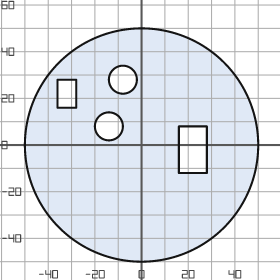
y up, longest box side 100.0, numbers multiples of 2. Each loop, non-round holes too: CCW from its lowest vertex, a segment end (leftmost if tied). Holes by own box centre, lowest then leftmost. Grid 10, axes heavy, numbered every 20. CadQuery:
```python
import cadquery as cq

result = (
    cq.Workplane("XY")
    .moveTo(0.0, 0.0)
    .circle(50.0)
    .moveTo(16.0, -12.0)
    .lineTo(28.0, -12.0)
    .lineTo(28.0, 8.0)
    .lineTo(16.0, 8.0)
    .close()
    .moveTo(-14.0, 8.0)
    .circle(6.0)
    .moveTo(-36.0, 16.0)
    .lineTo(-28.0, 16.0)
    .lineTo(-28.0, 28.0)
    .lineTo(-36.0, 28.0)
    .close()
    .moveTo(-8.0, 28.0)
    .circle(6.0)
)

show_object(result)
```